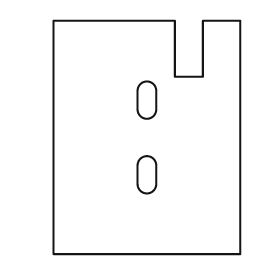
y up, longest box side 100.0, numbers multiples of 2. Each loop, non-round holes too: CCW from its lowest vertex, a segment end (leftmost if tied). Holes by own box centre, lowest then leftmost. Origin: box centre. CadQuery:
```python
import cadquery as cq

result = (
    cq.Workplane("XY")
    .moveTo(-40.0, -50.0)
    .lineTo(40.0, -50.0)
    .lineTo(40.0, 50.0)
    .lineTo(24.0, 50.0)
    .lineTo(24.0, 26.0)
    .lineTo(12.0, 26.0)
    .lineTo(12.0, 50.0)
    .lineTo(-40.0, 50.0)
    .close()
    .moveTo(-4.0, -20.0)
    .threePointArc((0.0, -24.0), (4.0, -20.0))
    .lineTo(4.0, -12.0)
    .threePointArc((0.0, -8.0), (-4.0, -12.0))
    .close()
    .moveTo(-4.0, 12.0)
    .threePointArc((0.0, 8.0), (4.0, 12.0))
    .lineTo(4.0, 20.0)
    .threePointArc((0.0, 24.0), (-4.0, 20.0))
    .close()
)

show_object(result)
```